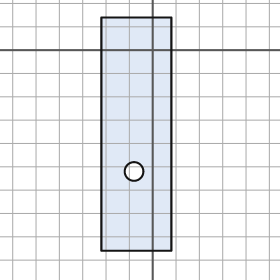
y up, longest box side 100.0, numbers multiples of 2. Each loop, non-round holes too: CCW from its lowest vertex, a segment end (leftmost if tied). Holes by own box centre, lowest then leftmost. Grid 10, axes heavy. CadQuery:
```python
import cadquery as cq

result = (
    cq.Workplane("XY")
    .moveTo(-22.0, -86.0)
    .lineTo(8.0, -86.0)
    .lineTo(8.0, 14.0)
    .lineTo(-22.0, 14.0)
    .close()
    .moveTo(-8.0, -52.0)
    .circle(4.0)
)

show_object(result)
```